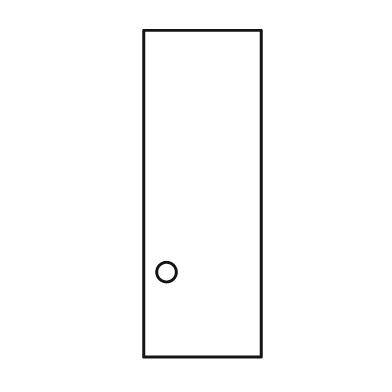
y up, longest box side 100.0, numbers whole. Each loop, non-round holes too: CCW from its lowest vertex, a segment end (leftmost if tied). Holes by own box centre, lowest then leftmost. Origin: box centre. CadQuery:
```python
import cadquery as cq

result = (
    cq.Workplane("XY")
    .moveTo(-18.0, -50.0)
    .lineTo(18.0, -50.0)
    .lineTo(18.0, 50.0)
    .lineTo(-18.0, 50.0)
    .close()
    .moveTo(-11.0, -24.0)
    .circle(3.0)
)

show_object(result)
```